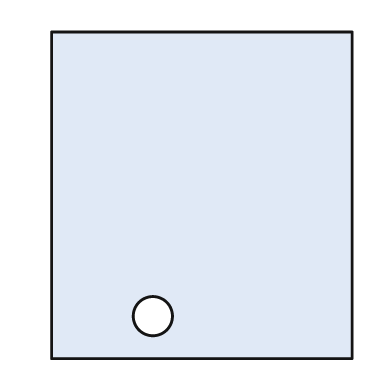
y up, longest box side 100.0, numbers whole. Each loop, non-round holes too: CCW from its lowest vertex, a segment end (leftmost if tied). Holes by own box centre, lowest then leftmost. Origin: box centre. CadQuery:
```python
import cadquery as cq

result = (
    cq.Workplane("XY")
    .moveTo(-46.0, -50.0)
    .lineTo(46.0, -50.0)
    .lineTo(46.0, 50.0)
    .lineTo(-46.0, 50.0)
    .close()
    .moveTo(-15.0, -37.0)
    .circle(6.0)
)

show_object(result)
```